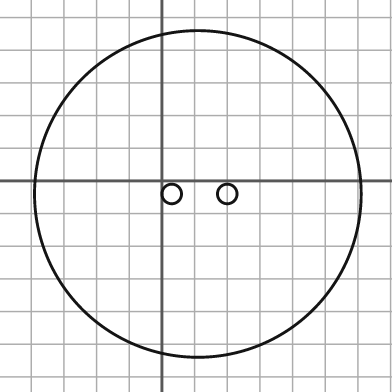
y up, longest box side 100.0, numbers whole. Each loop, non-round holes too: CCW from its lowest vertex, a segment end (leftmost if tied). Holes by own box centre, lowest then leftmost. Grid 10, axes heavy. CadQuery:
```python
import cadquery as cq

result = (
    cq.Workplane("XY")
    .moveTo(11.0, -4.0)
    .circle(50.0)
    .moveTo(3.0, -4.0)
    .circle(3.0)
    .moveTo(20.0, -4.0)
    .circle(3.0)
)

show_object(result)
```